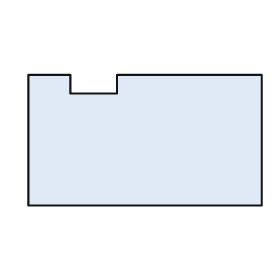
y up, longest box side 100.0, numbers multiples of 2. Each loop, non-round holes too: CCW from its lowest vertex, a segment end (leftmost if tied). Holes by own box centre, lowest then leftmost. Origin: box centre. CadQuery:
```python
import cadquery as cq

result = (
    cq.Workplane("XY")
    .moveTo(-50.0, -28.0)
    .lineTo(50.0, -28.0)
    .lineTo(50.0, 28.0)
    .lineTo(-12.0, 28.0)
    .lineTo(-12.0, 20.0)
    .lineTo(-32.0, 20.0)
    .lineTo(-32.0, 28.0)
    .lineTo(-50.0, 28.0)
    .close()
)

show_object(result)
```